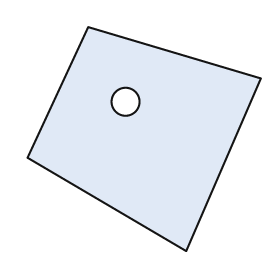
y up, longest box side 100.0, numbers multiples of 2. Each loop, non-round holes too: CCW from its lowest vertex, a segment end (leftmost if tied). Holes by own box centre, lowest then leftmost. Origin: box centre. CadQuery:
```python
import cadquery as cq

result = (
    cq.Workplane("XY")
    .moveTo(18.0, -48.0)
    .lineTo(50.0, 26.0)
    .lineTo(-24.0, 48.0)
    .lineTo(-50.0, -8.0)
    .close()
    .moveTo(-8.0, 16.0)
    .circle(6.0)
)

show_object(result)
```